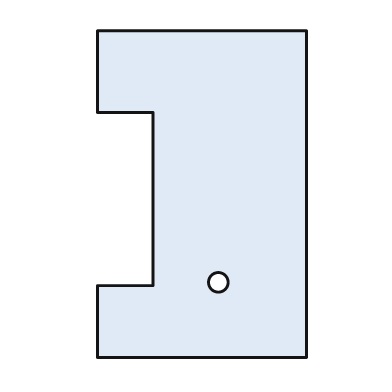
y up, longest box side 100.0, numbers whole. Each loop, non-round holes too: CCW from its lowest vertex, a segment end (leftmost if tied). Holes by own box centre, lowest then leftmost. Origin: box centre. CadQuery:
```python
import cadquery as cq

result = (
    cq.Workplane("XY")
    .moveTo(-32.0, -50.0)
    .lineTo(32.0, -50.0)
    .lineTo(32.0, 50.0)
    .lineTo(-32.0, 50.0)
    .lineTo(-32.0, 25.0)
    .lineTo(-15.0, 25.0)
    .lineTo(-15.0, -28.0)
    .lineTo(-32.0, -28.0)
    .close()
    .moveTo(5.0, -27.0)
    .circle(3.0)
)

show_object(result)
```